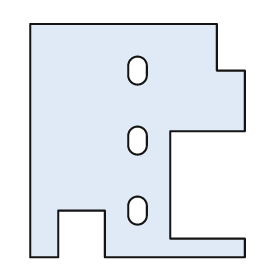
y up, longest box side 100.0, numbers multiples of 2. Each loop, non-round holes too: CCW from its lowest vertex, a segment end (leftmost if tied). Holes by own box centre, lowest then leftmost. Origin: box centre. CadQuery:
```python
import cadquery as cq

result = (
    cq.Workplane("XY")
    .moveTo(-46.0, -50.0)
    .lineTo(-34.0, -50.0)
    .lineTo(-34.0, -30.0)
    .lineTo(-14.0, -30.0)
    .lineTo(-14.0, -50.0)
    .lineTo(46.0, -50.0)
    .lineTo(46.0, -42.0)
    .lineTo(14.0, -42.0)
    .lineTo(14.0, 4.0)
    .lineTo(46.0, 4.0)
    .lineTo(46.0, 30.0)
    .lineTo(34.0, 30.0)
    .lineTo(34.0, 50.0)
    .lineTo(-46.0, 50.0)
    .close()
    .moveTo(-4.0, -32.0)
    .threePointArc((0.0, -36.0), (4.0, -32.0))
    .lineTo(4.0, -28.0)
    .threePointArc((0.0, -24.0), (-4.0, -28.0))
    .close()
    .moveTo(-4.0, -2.0)
    .threePointArc((0.0, -6.0), (4.0, -2.0))
    .lineTo(4.0, 2.0)
    .threePointArc((0.0, 6.0), (-4.0, 2.0))
    .close()
    .moveTo(-4.0, 28.0)
    .threePointArc((0.0, 24.0), (4.0, 28.0))
    .lineTo(4.0, 32.0)
    .threePointArc((0.0, 36.0), (-4.0, 32.0))
    .close()
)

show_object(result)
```